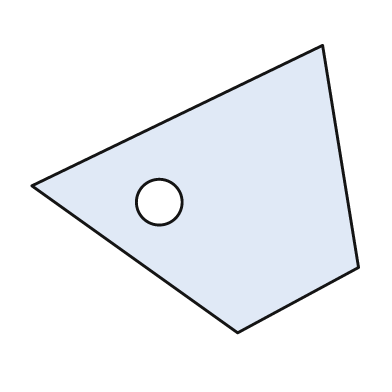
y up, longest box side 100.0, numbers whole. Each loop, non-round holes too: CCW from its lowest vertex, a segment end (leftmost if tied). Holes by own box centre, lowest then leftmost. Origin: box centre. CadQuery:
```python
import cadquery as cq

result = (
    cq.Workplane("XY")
    .moveTo(13.0, -44.0)
    .lineTo(50.0, -24.0)
    .lineTo(39.0, 44.0)
    .lineTo(-50.0, 1.0)
    .close()
    .moveTo(-11.0, -4.0)
    .circle(7.0)
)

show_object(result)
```